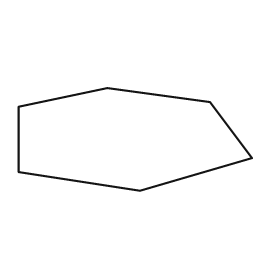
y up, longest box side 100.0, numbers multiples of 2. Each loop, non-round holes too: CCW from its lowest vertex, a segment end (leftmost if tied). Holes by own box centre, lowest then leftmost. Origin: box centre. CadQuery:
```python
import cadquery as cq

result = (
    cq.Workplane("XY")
    .moveTo(2.0, -22.0)
    .lineTo(50.0, -8.0)
    .lineTo(32.0, 16.0)
    .lineTo(-12.0, 22.0)
    .lineTo(-50.0, 14.0)
    .lineTo(-50.0, -14.0)
    .close()
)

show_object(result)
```